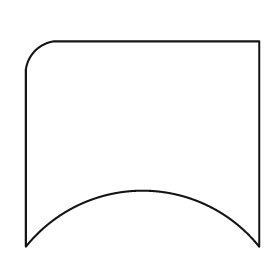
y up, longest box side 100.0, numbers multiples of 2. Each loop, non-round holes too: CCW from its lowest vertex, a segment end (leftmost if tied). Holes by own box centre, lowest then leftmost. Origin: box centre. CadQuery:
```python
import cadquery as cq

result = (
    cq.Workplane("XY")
    .moveTo(-50.0, -44.0)
    .threePointArc((0.0, -20.0), (50.0, -44.0))
    .lineTo(50.0, 44.0)
    .lineTo(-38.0, 44.0)
    .threePointArc((-46.0, 40.0), (-50.0, 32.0))
    .close()
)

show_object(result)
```